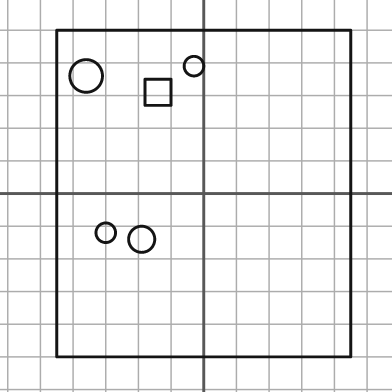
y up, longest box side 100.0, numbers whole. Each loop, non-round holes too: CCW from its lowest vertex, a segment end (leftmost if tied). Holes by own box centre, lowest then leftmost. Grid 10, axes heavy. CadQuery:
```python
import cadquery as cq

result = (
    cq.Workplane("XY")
    .moveTo(-45.0, -50.0)
    .lineTo(45.0, -50.0)
    .lineTo(45.0, 50.0)
    .lineTo(-45.0, 50.0)
    .close()
    .moveTo(-19.0, -14.0)
    .circle(4.0)
    .moveTo(-30.0, -12.0)
    .circle(3.0)
    .moveTo(-18.0, 27.0)
    .lineTo(-10.0, 27.0)
    .lineTo(-10.0, 35.0)
    .lineTo(-18.0, 35.0)
    .close()
    .moveTo(-36.0, 36.0)
    .circle(5.0)
    .moveTo(-3.0, 39.0)
    .circle(3.0)
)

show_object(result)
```